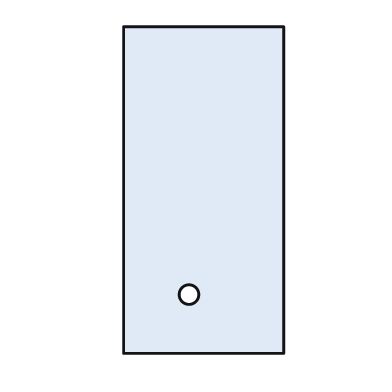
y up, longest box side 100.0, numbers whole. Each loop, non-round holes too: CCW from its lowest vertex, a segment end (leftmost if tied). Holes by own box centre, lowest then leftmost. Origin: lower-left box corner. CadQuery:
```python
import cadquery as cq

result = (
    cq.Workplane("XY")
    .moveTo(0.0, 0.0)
    .lineTo(49.0, 0.0)
    .lineTo(49.0, 100.0)
    .lineTo(0.0, 100.0)
    .close()
    .moveTo(20.0, 18.0)
    .circle(3.0)
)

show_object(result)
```